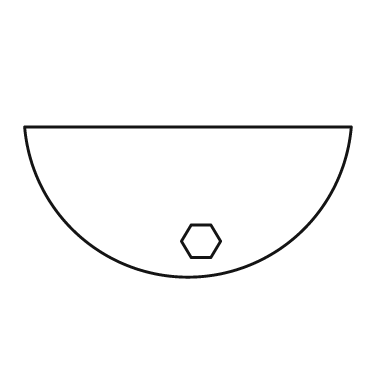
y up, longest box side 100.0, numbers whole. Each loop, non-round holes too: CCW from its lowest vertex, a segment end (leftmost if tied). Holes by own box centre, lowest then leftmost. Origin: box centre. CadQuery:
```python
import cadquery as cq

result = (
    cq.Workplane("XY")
    .moveTo(-50.0, 23.0)
    .threePointArc((0.0, -23.0), (50.0, 23.0))
    .close()
    .moveTo(1.0, -17.0)
    .lineTo(7.0, -17.0)
    .lineTo(10.0, -12.0)
    .lineTo(7.0, -7.0)
    .lineTo(1.0, -7.0)
    .lineTo(-2.0, -12.0)
    .close()
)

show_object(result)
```